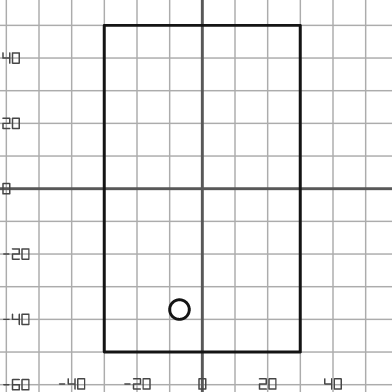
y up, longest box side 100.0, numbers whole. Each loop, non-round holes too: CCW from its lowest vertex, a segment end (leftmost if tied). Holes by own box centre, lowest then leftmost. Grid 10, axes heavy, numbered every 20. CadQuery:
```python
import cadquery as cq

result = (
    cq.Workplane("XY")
    .moveTo(-30.0, -50.0)
    .lineTo(30.0, -50.0)
    .lineTo(30.0, 50.0)
    .lineTo(-30.0, 50.0)
    .close()
    .moveTo(-7.0, -37.0)
    .circle(3.0)
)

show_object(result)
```